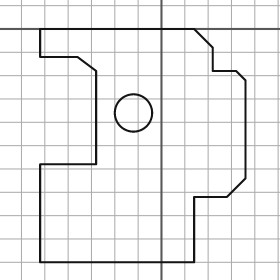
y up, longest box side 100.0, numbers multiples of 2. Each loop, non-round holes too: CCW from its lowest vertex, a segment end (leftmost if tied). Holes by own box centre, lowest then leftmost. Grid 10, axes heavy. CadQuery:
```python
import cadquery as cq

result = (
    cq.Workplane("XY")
    .moveTo(-52.0, -100.0)
    .lineTo(14.0, -100.0)
    .lineTo(14.0, -72.0)
    .lineTo(28.0, -72.0)
    .lineTo(36.0, -64.0)
    .lineTo(36.0, -22.0)
    .lineTo(32.0, -18.0)
    .lineTo(22.0, -18.0)
    .lineTo(22.0, -8.0)
    .lineTo(14.0, 0.0)
    .lineTo(-52.0, 0.0)
    .lineTo(-52.0, -12.0)
    .lineTo(-36.0, -12.0)
    .lineTo(-28.0, -18.0)
    .lineTo(-28.0, -58.0)
    .lineTo(-52.0, -58.0)
    .close()
    .moveTo(-12.0, -36.0)
    .circle(8.0)
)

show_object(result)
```